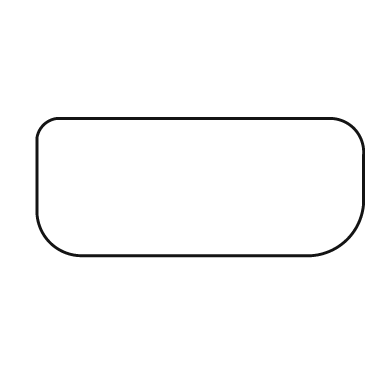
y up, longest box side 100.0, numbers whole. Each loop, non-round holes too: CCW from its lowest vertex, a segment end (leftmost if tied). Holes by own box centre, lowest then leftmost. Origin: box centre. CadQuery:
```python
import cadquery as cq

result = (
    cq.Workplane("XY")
    .moveTo(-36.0, -21.0)
    .lineTo(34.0, -21.0)
    .threePointArc((45.0, -16.0), (50.0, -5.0))
    .lineTo(50.0, 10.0)
    .threePointArc((47.0, 18.0), (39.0, 21.0))
    .lineTo(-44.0, 21.0)
    .threePointArc((-48.0, 19.0), (-50.0, 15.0))
    .lineTo(-50.0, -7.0)
    .threePointArc((-46.0, -17.0), (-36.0, -21.0))
    .close()
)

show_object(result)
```